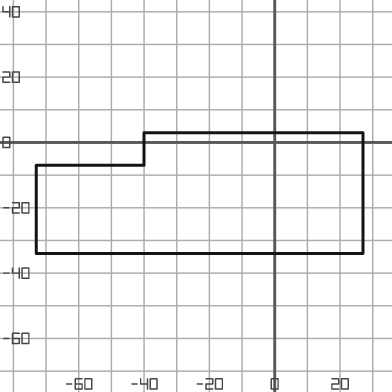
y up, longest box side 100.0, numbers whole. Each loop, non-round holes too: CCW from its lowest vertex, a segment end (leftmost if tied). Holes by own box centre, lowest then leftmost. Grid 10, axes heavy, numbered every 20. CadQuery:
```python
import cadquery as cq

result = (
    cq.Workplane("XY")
    .moveTo(-73.0, -34.0)
    .lineTo(27.0, -34.0)
    .lineTo(27.0, 3.0)
    .lineTo(-40.0, 3.0)
    .lineTo(-40.0, -7.0)
    .lineTo(-73.0, -7.0)
    .close()
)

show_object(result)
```